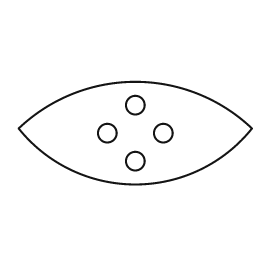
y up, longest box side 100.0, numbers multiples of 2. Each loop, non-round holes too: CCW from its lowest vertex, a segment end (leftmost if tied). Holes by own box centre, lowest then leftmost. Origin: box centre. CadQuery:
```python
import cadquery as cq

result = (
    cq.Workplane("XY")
    .moveTo(-50.0, 2.0)
    .threePointArc((0.0, -22.0), (50.0, 2.0))
    .threePointArc((0.0, 22.0), (-50.0, 2.0))
    .close()
    .moveTo(0.0, -12.0)
    .circle(4.0)
    .moveTo(-12.0, 0.0)
    .circle(4.0)
    .moveTo(12.0, 0.0)
    .circle(4.0)
    .moveTo(0.0, 12.0)
    .circle(4.0)
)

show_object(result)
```